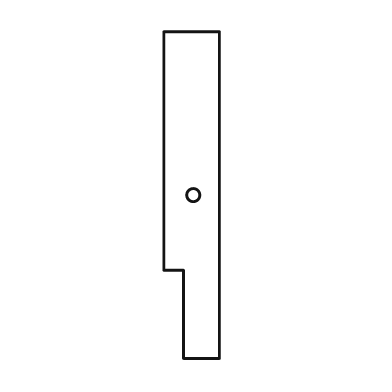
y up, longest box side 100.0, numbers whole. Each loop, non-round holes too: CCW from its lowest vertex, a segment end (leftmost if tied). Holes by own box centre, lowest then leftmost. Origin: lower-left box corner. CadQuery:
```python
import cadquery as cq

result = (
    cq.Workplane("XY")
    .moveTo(6.0, 0.0)
    .lineTo(17.0, 0.0)
    .lineTo(17.0, 100.0)
    .lineTo(0.0, 100.0)
    .lineTo(0.0, 27.0)
    .lineTo(6.0, 27.0)
    .close()
    .moveTo(9.0, 50.0)
    .circle(2.0)
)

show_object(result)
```